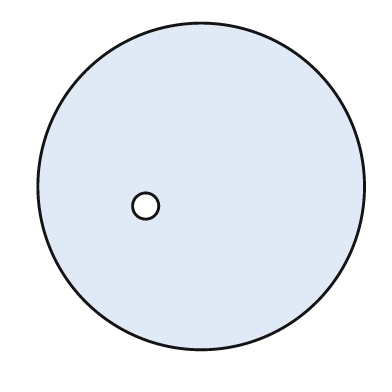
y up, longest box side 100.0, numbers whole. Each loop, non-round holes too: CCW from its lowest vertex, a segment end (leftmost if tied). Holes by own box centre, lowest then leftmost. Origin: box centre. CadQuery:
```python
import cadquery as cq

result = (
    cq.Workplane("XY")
    .moveTo(0.0, 0.0)
    .circle(50.0)
    .moveTo(-17.0, -6.0)
    .circle(4.0)
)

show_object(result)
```